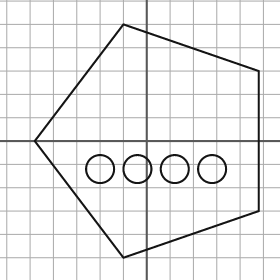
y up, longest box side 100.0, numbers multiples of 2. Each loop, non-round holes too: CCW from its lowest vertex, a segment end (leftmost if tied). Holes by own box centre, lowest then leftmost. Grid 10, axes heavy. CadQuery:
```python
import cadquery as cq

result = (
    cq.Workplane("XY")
    .moveTo(-10.0, -50.0)
    .lineTo(48.0, -30.0)
    .lineTo(48.0, 30.0)
    .lineTo(-10.0, 50.0)
    .lineTo(-48.0, 0.0)
    .close()
    .moveTo(-20.0, -12.0)
    .circle(6.0)
    .moveTo(-4.0, -12.0)
    .circle(6.0)
    .moveTo(12.0, -12.0)
    .circle(6.0)
    .moveTo(28.0, -12.0)
    .circle(6.0)
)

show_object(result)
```